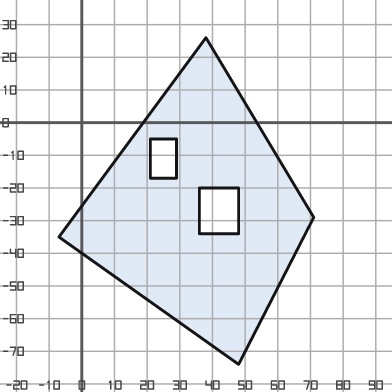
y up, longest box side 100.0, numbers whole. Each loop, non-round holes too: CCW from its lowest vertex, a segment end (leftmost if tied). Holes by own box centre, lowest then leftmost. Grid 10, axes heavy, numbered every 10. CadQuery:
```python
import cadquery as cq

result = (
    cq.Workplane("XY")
    .moveTo(48.0, -74.0)
    .lineTo(71.0, -29.0)
    .lineTo(38.0, 26.0)
    .lineTo(-7.0, -35.0)
    .close()
    .moveTo(36.0, -34.0)
    .lineTo(48.0, -34.0)
    .lineTo(48.0, -20.0)
    .lineTo(36.0, -20.0)
    .close()
    .moveTo(21.0, -17.0)
    .lineTo(29.0, -17.0)
    .lineTo(29.0, -5.0)
    .lineTo(21.0, -5.0)
    .close()
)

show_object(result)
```